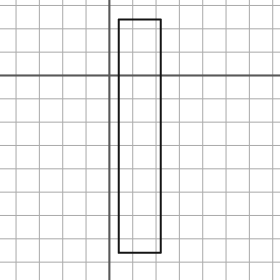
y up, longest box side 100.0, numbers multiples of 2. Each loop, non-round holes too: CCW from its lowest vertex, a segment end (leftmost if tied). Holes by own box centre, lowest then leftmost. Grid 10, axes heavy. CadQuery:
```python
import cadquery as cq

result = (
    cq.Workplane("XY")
    .moveTo(4.0, -76.0)
    .lineTo(22.0, -76.0)
    .lineTo(22.0, 24.0)
    .lineTo(4.0, 24.0)
    .close()
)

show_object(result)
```